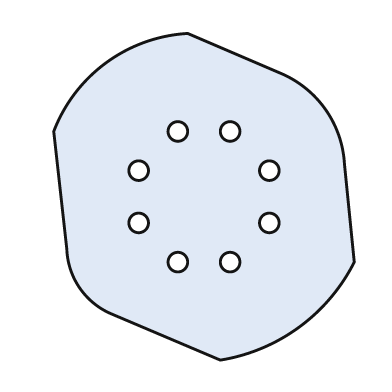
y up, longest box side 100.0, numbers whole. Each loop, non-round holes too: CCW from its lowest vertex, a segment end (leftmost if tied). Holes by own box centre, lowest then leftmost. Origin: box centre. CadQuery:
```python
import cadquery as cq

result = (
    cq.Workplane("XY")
    .moveTo(5.0, -50.0)
    .threePointArc((29.0, -40.0), (46.0, -20.0))
    .lineTo(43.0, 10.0)
    .threePointArc((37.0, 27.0), (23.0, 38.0))
    .lineTo(-5.0, 50.0)
    .threePointArc((-30.0, 41.0), (-46.0, 20.0))
    .lineTo(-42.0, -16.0)
    .threePointArc((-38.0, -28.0), (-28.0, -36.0))
    .close()
    .moveTo(-8.0, -20.0)
    .circle(3.0)
    .moveTo(8.0, -20.0)
    .circle(3.0)
    .moveTo(-20.0, -8.0)
    .circle(3.0)
    .moveTo(20.0, -8.0)
    .circle(3.0)
    .moveTo(-20.0, 8.0)
    .circle(3.0)
    .moveTo(20.0, 8.0)
    .circle(3.0)
    .moveTo(-8.0, 20.0)
    .circle(3.0)
    .moveTo(8.0, 20.0)
    .circle(3.0)
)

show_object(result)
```